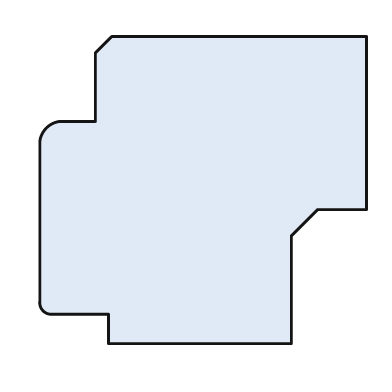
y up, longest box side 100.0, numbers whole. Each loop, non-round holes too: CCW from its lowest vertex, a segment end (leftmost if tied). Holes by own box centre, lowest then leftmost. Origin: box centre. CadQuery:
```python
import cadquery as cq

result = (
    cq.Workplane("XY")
    .moveTo(-29.0, -47.0)
    .lineTo(27.0, -47.0)
    .lineTo(27.0, -14.0)
    .lineTo(35.0, -6.0)
    .lineTo(50.0, -6.0)
    .lineTo(50.0, 47.0)
    .lineTo(-28.0, 47.0)
    .lineTo(-33.0, 42.0)
    .lineTo(-33.0, 21.0)
    .lineTo(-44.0, 21.0)
    .threePointArc((-48.0, 19.0), (-50.0, 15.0))
    .lineTo(-50.0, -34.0)
    .threePointArc((-49.0, -37.0), (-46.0, -38.0))
    .lineTo(-29.0, -38.0)
    .close()
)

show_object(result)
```